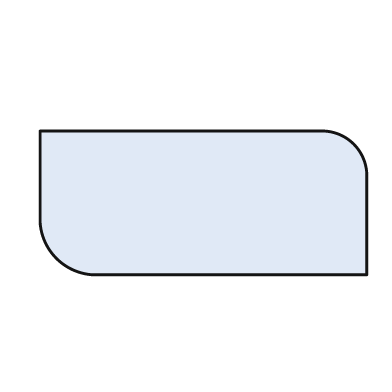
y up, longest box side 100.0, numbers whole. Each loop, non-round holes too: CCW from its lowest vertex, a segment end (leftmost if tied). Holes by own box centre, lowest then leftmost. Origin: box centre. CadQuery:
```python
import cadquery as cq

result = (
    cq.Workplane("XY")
    .moveTo(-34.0, -22.0)
    .lineTo(50.0, -22.0)
    .lineTo(50.0, 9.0)
    .threePointArc((46.0, 18.0), (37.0, 22.0))
    .lineTo(-50.0, 22.0)
    .lineTo(-50.0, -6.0)
    .threePointArc((-45.0, -17.0), (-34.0, -22.0))
    .close()
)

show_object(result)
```